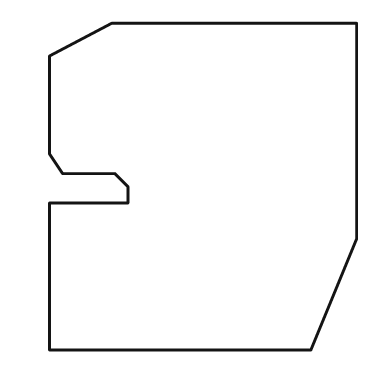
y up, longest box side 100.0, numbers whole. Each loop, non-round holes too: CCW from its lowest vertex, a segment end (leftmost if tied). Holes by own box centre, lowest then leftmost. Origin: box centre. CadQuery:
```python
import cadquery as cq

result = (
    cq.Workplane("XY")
    .moveTo(-47.0, -50.0)
    .lineTo(33.0, -50.0)
    .lineTo(47.0, -16.0)
    .lineTo(47.0, 50.0)
    .lineTo(-28.0, 50.0)
    .lineTo(-47.0, 40.0)
    .lineTo(-47.0, 10.0)
    .lineTo(-43.0, 4.0)
    .lineTo(-27.0, 4.0)
    .lineTo(-23.0, 0.0)
    .lineTo(-23.0, -5.0)
    .lineTo(-47.0, -5.0)
    .close()
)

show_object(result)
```